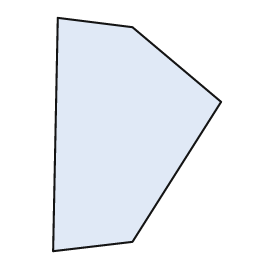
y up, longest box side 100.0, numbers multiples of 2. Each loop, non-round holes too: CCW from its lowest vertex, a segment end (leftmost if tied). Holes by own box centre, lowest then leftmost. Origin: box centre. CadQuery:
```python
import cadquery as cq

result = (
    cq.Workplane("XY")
    .moveTo(-36.0, -50.0)
    .lineTo(-2.0, -46.0)
    .lineTo(36.0, 14.0)
    .lineTo(-2.0, 46.0)
    .lineTo(-34.0, 50.0)
    .close()
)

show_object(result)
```